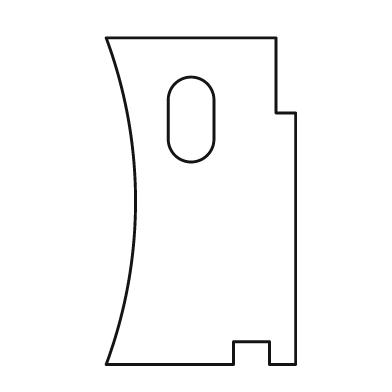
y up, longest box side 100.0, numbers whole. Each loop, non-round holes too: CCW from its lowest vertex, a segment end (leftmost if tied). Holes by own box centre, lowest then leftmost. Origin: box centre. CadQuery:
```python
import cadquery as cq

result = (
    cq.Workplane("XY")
    .moveTo(-29.0, -50.0)
    .lineTo(10.0, -50.0)
    .lineTo(10.0, -43.0)
    .lineTo(21.0, -43.0)
    .lineTo(21.0, -50.0)
    .lineTo(29.0, -50.0)
    .lineTo(29.0, 27.0)
    .lineTo(23.0, 27.0)
    .lineTo(23.0, 50.0)
    .lineTo(-29.0, 50.0)
    .threePointArc((-20.0, 0.0), (-29.0, -50.0))
    .close()
    .moveTo(-10.0, 19.0)
    .threePointArc((-3.0, 12.0), (4.0, 19.0))
    .lineTo(4.0, 31.0)
    .threePointArc((-3.0, 38.0), (-10.0, 31.0))
    .close()
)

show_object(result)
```